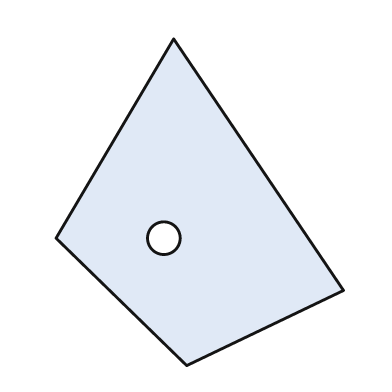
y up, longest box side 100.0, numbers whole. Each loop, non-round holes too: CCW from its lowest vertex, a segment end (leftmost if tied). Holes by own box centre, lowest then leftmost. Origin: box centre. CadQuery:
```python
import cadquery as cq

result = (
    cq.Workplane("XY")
    .moveTo(-4.0, -50.0)
    .lineTo(44.0, -27.0)
    .lineTo(-8.0, 50.0)
    .lineTo(-44.0, -11.0)
    .close()
    .moveTo(-11.0, -11.0)
    .circle(5.0)
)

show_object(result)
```